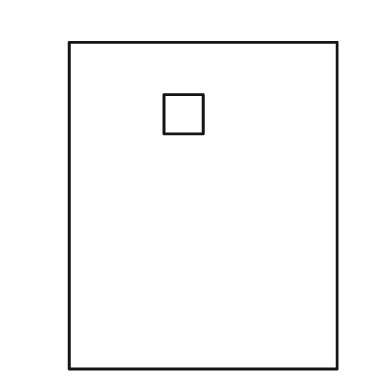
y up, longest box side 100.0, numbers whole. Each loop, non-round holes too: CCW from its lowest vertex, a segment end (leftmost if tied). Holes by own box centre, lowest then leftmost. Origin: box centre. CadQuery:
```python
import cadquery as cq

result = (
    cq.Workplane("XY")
    .moveTo(-41.0, -50.0)
    .lineTo(41.0, -50.0)
    .lineTo(41.0, 50.0)
    .lineTo(-41.0, 50.0)
    .close()
    .moveTo(-12.0, 22.0)
    .lineTo(0.0, 22.0)
    .lineTo(0.0, 34.0)
    .lineTo(-12.0, 34.0)
    .close()
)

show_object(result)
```